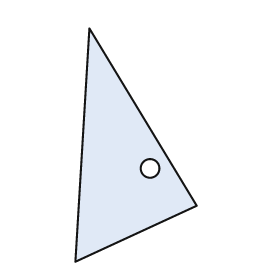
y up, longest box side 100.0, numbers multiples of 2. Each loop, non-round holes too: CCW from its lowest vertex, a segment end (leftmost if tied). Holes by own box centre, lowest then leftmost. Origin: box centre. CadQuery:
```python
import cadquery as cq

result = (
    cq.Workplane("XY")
    .moveTo(-26.0, -50.0)
    .lineTo(26.0, -26.0)
    .lineTo(-20.0, 50.0)
    .close()
    .moveTo(6.0, -10.0)
    .circle(4.0)
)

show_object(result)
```